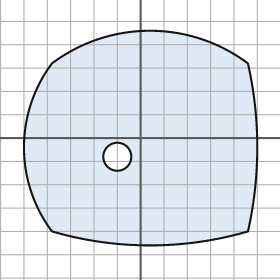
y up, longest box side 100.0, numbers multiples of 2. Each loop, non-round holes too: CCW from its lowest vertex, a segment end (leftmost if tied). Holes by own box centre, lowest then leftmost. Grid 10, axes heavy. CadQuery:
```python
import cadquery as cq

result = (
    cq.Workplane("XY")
    .moveTo(-38.0, -40.0)
    .threePointArc((4.0, -46.0), (46.0, -40.0))
    .threePointArc((50.0, -4.0), (46.0, 32.0))
    .threePointArc((4.0, 46.0), (-38.0, 32.0))
    .threePointArc((-50.0, -4.0), (-38.0, -40.0))
    .close()
    .moveTo(-10.0, -8.0)
    .circle(6.0)
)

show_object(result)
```